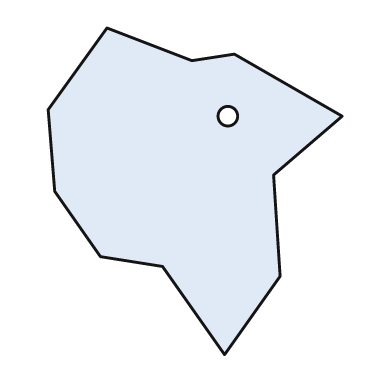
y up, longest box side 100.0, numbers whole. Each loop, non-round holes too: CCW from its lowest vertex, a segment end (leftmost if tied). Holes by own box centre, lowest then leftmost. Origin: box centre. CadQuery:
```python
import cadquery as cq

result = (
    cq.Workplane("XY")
    .moveTo(9.0, -50.0)
    .lineTo(26.0, -26.0)
    .lineTo(24.0, 5.0)
    .lineTo(45.0, 23.0)
    .lineTo(12.0, 42.0)
    .lineTo(-1.0, 40.0)
    .lineTo(-27.0, 50.0)
    .lineTo(-45.0, 25.0)
    .lineTo(-43.0, 0.0)
    .lineTo(-29.0, -20.0)
    .lineTo(-10.0, -23.0)
    .close()
    .moveTo(10.0, 23.0)
    .circle(3.0)
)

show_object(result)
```